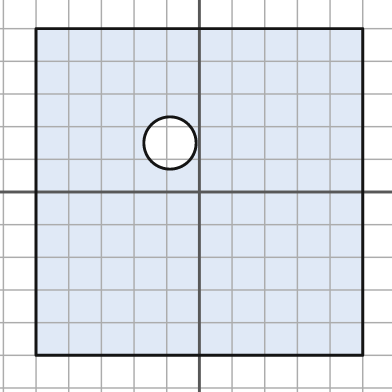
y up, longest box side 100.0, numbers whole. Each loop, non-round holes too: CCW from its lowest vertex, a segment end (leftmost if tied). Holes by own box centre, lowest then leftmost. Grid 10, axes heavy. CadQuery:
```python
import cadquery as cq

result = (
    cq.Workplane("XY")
    .moveTo(-50.0, -50.0)
    .lineTo(50.0, -50.0)
    .lineTo(50.0, 50.0)
    .lineTo(-50.0, 50.0)
    .close()
    .moveTo(-9.0, 15.0)
    .circle(8.0)
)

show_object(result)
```